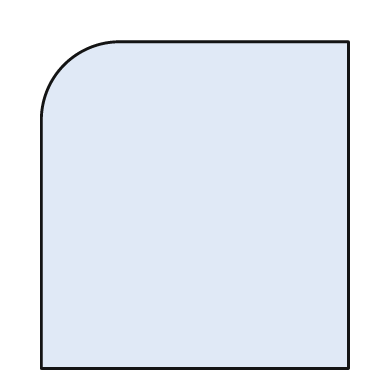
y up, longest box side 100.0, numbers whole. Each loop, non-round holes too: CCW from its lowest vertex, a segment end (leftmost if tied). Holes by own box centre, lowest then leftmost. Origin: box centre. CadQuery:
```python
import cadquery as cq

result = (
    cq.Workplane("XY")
    .moveTo(-47.0, -50.0)
    .lineTo(47.0, -50.0)
    .lineTo(47.0, 50.0)
    .lineTo(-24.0, 50.0)
    .threePointArc((-40.0, 43.0), (-47.0, 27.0))
    .close()
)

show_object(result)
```